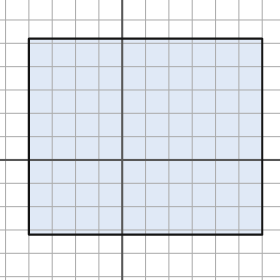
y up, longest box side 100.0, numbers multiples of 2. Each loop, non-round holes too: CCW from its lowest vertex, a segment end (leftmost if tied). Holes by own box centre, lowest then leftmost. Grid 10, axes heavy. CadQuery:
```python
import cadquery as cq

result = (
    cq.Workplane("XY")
    .moveTo(-40.0, -32.0)
    .lineTo(60.0, -32.0)
    .lineTo(60.0, 52.0)
    .lineTo(-40.0, 52.0)
    .close()
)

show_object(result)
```